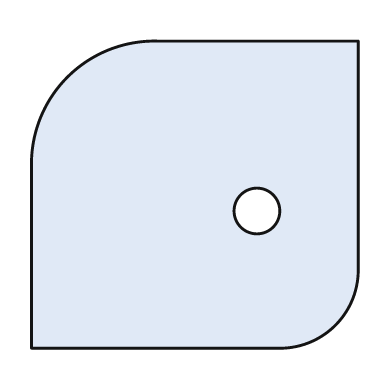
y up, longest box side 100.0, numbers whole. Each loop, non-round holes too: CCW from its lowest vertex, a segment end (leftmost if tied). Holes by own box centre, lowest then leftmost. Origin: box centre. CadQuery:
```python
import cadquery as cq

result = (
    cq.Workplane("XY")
    .moveTo(-50.0, -47.0)
    .lineTo(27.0, -47.0)
    .threePointArc((43.0, -40.0), (50.0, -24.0))
    .lineTo(50.0, 47.0)
    .lineTo(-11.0, 47.0)
    .threePointArc((-39.0, 36.0), (-50.0, 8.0))
    .close()
    .moveTo(19.0, -5.0)
    .circle(7.0)
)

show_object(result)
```